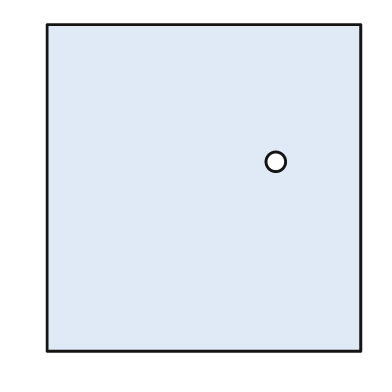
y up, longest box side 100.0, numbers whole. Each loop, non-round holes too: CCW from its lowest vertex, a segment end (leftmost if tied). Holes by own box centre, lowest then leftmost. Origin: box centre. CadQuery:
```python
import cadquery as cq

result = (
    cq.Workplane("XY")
    .moveTo(-48.0, -50.0)
    .lineTo(48.0, -50.0)
    .lineTo(48.0, 50.0)
    .lineTo(-48.0, 50.0)
    .close()
    .moveTo(22.0, 8.0)
    .circle(3.0)
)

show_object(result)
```